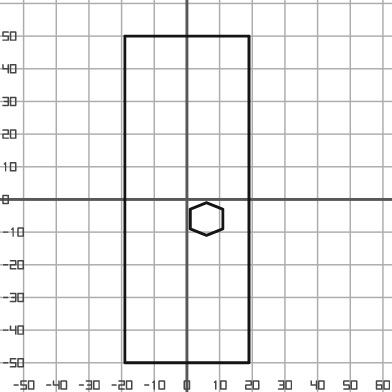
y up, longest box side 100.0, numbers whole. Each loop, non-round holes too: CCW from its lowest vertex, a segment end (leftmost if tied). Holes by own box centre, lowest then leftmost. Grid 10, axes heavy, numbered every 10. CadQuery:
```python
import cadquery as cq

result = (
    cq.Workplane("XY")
    .moveTo(-19.0, -50.0)
    .lineTo(19.0, -50.0)
    .lineTo(19.0, 50.0)
    .lineTo(-19.0, 50.0)
    .close()
    .moveTo(6.0, -11.0)
    .lineTo(11.0, -9.0)
    .lineTo(11.0, -3.0)
    .lineTo(6.0, -1.0)
    .lineTo(1.0, -3.0)
    .lineTo(1.0, -9.0)
    .close()
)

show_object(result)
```